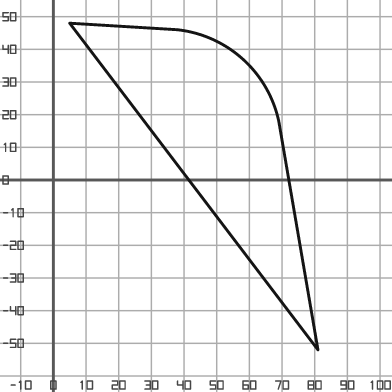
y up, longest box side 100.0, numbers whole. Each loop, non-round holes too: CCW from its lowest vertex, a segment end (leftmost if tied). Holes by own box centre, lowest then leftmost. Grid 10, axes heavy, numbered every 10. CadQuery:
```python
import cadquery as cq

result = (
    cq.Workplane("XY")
    .moveTo(81.0, -52.0)
    .lineTo(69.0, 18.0)
    .threePointArc((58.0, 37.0), (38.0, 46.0))
    .lineTo(5.0, 48.0)
    .close()
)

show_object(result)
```